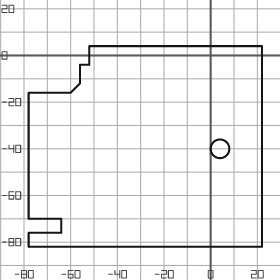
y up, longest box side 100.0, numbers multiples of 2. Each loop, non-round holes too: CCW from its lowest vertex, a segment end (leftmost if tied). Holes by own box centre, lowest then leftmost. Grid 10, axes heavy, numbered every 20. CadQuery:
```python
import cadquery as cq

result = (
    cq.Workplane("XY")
    .moveTo(-78.0, -82.0)
    .lineTo(22.0, -82.0)
    .lineTo(22.0, 4.0)
    .lineTo(-52.0, 4.0)
    .lineTo(-52.0, -4.0)
    .lineTo(-56.0, -4.0)
    .lineTo(-56.0, -12.0)
    .lineTo(-60.0, -16.0)
    .lineTo(-78.0, -16.0)
    .lineTo(-78.0, -70.0)
    .lineTo(-64.0, -70.0)
    .lineTo(-64.0, -76.0)
    .lineTo(-78.0, -76.0)
    .close()
    .moveTo(4.0, -40.0)
    .circle(4.0)
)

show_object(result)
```